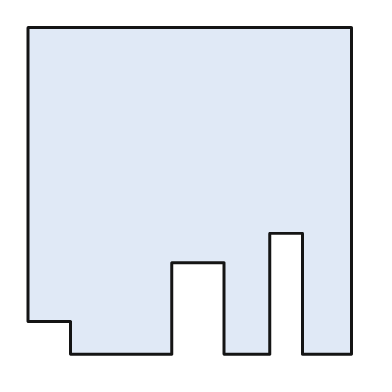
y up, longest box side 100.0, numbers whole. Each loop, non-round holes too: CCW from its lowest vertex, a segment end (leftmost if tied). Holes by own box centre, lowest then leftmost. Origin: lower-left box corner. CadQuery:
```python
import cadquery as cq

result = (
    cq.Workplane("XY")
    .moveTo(13.0, 0.0)
    .lineTo(44.0, 0.0)
    .lineTo(44.0, 28.0)
    .lineTo(60.0, 28.0)
    .lineTo(60.0, 0.0)
    .lineTo(74.0, 0.0)
    .lineTo(74.0, 37.0)
    .lineTo(84.0, 37.0)
    .lineTo(84.0, 0.0)
    .lineTo(99.0, 0.0)
    .lineTo(99.0, 100.0)
    .lineTo(0.0, 100.0)
    .lineTo(0.0, 10.0)
    .lineTo(13.0, 10.0)
    .close()
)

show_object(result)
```